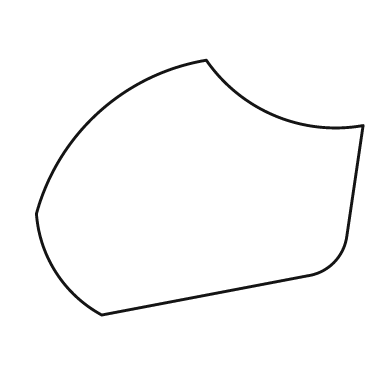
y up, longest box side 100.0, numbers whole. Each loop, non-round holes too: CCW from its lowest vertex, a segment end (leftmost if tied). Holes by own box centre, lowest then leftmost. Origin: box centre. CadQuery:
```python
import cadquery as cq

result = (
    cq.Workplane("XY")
    .moveTo(-30.0, -39.0)
    .lineTo(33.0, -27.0)
    .threePointArc((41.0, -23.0), (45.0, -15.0))
    .lineTo(50.0, 19.0)
    .threePointArc((23.0, 22.0), (2.0, 39.0))
    .threePointArc((-31.0, 23.0), (-50.0, -8.0))
    .threePointArc((-44.0, -26.0), (-30.0, -39.0))
    .close()
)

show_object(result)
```